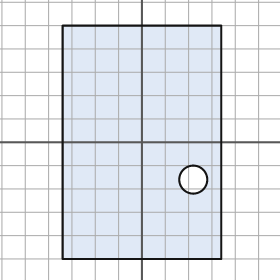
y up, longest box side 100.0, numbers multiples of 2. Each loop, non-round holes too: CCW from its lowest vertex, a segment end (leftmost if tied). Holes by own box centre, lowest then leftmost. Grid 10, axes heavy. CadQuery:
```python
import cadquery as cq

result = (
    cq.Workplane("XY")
    .moveTo(-34.0, -50.0)
    .lineTo(34.0, -50.0)
    .lineTo(34.0, 50.0)
    .lineTo(-34.0, 50.0)
    .close()
    .moveTo(22.0, -16.0)
    .circle(6.0)
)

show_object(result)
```